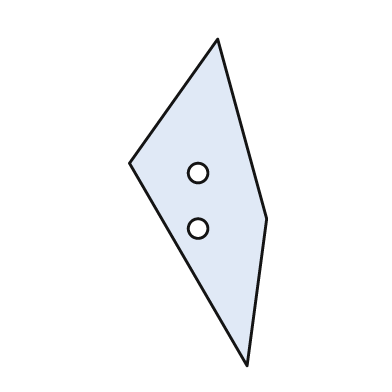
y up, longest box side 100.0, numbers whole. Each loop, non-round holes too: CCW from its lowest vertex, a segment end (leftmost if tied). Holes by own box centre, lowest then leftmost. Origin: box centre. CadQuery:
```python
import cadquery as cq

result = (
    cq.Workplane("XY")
    .moveTo(15.0, -50.0)
    .lineTo(21.0, -5.0)
    .lineTo(6.0, 50.0)
    .lineTo(-21.0, 12.0)
    .close()
    .moveTo(0.0, -8.0)
    .circle(3.0)
    .moveTo(0.0, 9.0)
    .circle(3.0)
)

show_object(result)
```